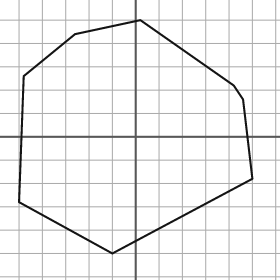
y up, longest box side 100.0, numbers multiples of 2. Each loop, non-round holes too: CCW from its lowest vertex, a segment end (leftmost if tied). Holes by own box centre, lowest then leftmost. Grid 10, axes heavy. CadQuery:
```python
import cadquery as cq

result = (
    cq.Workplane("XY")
    .moveTo(-10.0, -50.0)
    .lineTo(50.0, -18.0)
    .lineTo(46.0, 16.0)
    .lineTo(42.0, 22.0)
    .lineTo(2.0, 50.0)
    .lineTo(-26.0, 44.0)
    .lineTo(-48.0, 26.0)
    .lineTo(-50.0, -28.0)
    .close()
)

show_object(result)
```